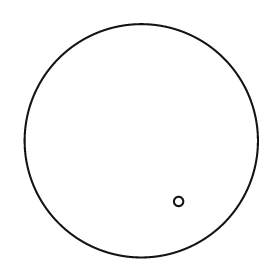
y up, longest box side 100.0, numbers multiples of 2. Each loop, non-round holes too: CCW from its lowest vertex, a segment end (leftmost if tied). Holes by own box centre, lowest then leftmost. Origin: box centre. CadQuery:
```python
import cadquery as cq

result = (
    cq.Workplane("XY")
    .moveTo(0.0, 0.0)
    .circle(50.0)
    .moveTo(16.0, -26.0)
    .circle(2.0)
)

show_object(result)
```